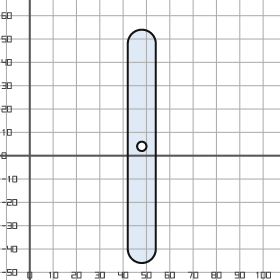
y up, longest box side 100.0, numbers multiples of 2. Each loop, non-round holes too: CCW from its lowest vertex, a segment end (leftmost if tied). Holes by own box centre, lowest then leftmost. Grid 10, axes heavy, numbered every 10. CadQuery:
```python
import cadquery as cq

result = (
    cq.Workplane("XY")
    .moveTo(42.0, -40.0)
    .threePointArc((48.0, -46.0), (54.0, -40.0))
    .lineTo(54.0, 48.0)
    .threePointArc((48.0, 54.0), (42.0, 48.0))
    .close()
    .moveTo(48.0, 4.0)
    .circle(2.0)
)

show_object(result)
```